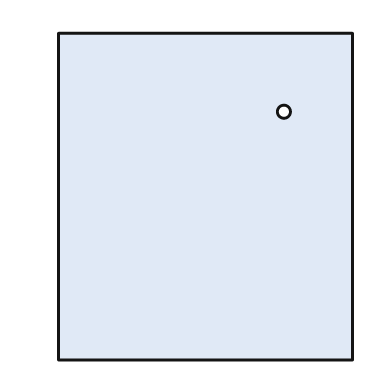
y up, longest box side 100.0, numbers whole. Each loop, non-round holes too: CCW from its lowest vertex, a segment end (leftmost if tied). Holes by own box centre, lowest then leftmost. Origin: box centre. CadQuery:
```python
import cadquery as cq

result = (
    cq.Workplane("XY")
    .moveTo(-45.0, -50.0)
    .lineTo(45.0, -50.0)
    .lineTo(45.0, 50.0)
    .lineTo(-45.0, 50.0)
    .close()
    .moveTo(24.0, 26.0)
    .circle(2.0)
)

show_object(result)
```